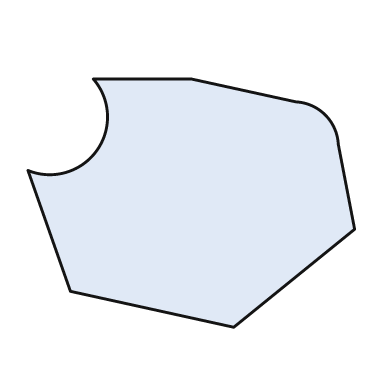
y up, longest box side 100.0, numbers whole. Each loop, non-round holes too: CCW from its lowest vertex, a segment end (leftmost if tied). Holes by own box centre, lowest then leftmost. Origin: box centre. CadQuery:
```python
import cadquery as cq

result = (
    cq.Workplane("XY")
    .moveTo(13.0, -38.0)
    .lineTo(50.0, -8.0)
    .lineTo(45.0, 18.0)
    .threePointArc((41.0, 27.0), (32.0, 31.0))
    .lineTo(0.0, 38.0)
    .lineTo(-30.0, 38.0)
    .threePointArc((-29.0, 16.0), (-50.0, 10.0))
    .lineTo(-37.0, -27.0)
    .close()
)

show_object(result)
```